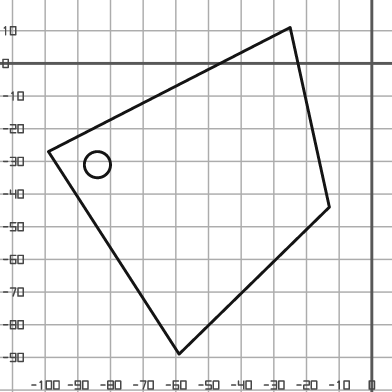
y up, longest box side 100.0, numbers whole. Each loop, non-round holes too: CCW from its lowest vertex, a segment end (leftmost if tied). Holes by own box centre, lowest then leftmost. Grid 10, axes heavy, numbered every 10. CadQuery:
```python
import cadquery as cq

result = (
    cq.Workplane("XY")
    .moveTo(-59.0, -89.0)
    .lineTo(-13.0, -44.0)
    .lineTo(-25.0, 11.0)
    .lineTo(-99.0, -27.0)
    .close()
    .moveTo(-84.0, -31.0)
    .circle(4.0)
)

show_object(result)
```